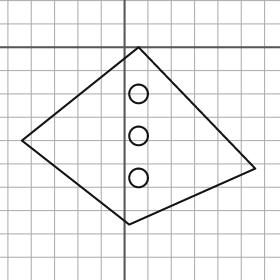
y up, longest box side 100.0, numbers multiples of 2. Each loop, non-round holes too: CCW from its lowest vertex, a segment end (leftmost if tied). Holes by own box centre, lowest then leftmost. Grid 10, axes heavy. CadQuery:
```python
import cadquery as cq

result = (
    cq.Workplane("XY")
    .moveTo(2.0, -76.0)
    .lineTo(56.0, -52.0)
    .lineTo(6.0, 0.0)
    .lineTo(-44.0, -40.0)
    .close()
    .moveTo(6.0, -56.0)
    .circle(4.0)
    .moveTo(6.0, -38.0)
    .circle(4.0)
    .moveTo(6.0, -20.0)
    .circle(4.0)
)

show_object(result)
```